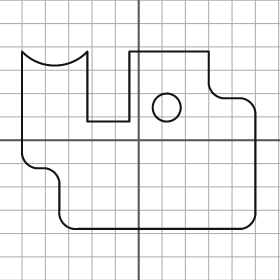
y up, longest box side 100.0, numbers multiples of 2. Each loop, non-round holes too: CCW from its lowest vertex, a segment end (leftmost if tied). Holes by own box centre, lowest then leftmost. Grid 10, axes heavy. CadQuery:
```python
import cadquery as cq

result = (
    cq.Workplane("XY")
    .moveTo(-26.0, -38.0)
    .lineTo(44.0, -38.0)
    .threePointArc((48.0, -36.0), (50.0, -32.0))
    .lineTo(50.0, 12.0)
    .threePointArc((48.0, 16.0), (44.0, 18.0))
    .lineTo(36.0, 18.0)
    .threePointArc((32.0, 20.0), (30.0, 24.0))
    .lineTo(30.0, 38.0)
    .lineTo(-4.0, 38.0)
    .lineTo(-4.0, 8.0)
    .lineTo(-22.0, 8.0)
    .lineTo(-22.0, 38.0)
    .threePointArc((-36.0, 32.0), (-50.0, 38.0))
    .lineTo(-50.0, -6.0)
    .threePointArc((-48.0, -10.0), (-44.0, -12.0))
    .lineTo(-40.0, -12.0)
    .threePointArc((-36.0, -14.0), (-34.0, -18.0))
    .lineTo(-34.0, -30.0)
    .threePointArc((-32.0, -36.0), (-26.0, -38.0))
    .close()
    .moveTo(12.0, 14.0)
    .circle(6.0)
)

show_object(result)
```